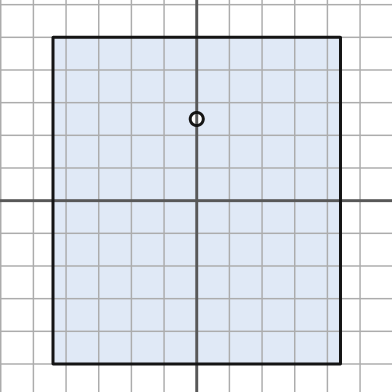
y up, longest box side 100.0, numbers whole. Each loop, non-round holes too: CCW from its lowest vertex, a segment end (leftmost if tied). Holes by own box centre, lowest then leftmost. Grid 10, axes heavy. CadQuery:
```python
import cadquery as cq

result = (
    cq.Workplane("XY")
    .moveTo(-44.0, -50.0)
    .lineTo(44.0, -50.0)
    .lineTo(44.0, 50.0)
    .lineTo(-44.0, 50.0)
    .close()
    .moveTo(0.0, 25.0)
    .circle(2.0)
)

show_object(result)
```